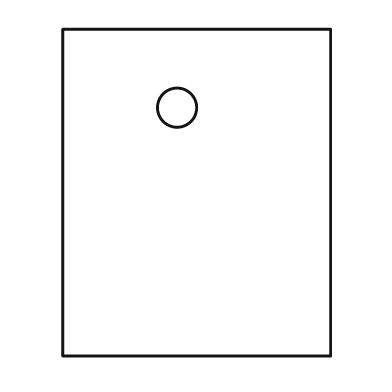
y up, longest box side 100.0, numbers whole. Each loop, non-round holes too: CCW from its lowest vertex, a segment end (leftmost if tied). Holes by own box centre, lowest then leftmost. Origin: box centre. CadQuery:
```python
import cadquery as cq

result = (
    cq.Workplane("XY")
    .moveTo(-41.0, -50.0)
    .lineTo(41.0, -50.0)
    .lineTo(41.0, 50.0)
    .lineTo(-41.0, 50.0)
    .close()
    .moveTo(-6.0, 26.0)
    .circle(6.0)
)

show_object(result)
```